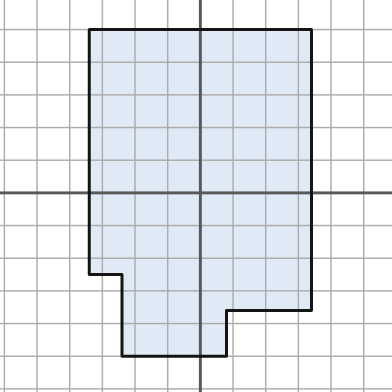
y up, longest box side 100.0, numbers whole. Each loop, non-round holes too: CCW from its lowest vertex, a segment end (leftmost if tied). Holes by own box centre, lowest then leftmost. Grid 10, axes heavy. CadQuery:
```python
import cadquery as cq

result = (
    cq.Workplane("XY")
    .moveTo(-24.0, -50.0)
    .lineTo(8.0, -50.0)
    .lineTo(8.0, -36.0)
    .lineTo(34.0, -36.0)
    .lineTo(34.0, 50.0)
    .lineTo(-34.0, 50.0)
    .lineTo(-34.0, -25.0)
    .lineTo(-24.0, -25.0)
    .close()
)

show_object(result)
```